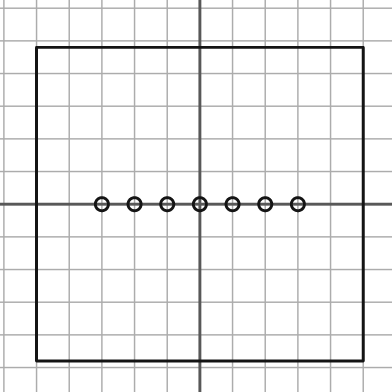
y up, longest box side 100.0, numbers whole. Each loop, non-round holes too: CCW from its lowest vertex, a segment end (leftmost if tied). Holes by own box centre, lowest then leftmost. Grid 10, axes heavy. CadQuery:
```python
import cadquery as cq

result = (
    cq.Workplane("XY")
    .moveTo(-50.0, -48.0)
    .lineTo(50.0, -48.0)
    .lineTo(50.0, 48.0)
    .lineTo(-50.0, 48.0)
    .close()
    .moveTo(-30.0, 0.0)
    .circle(2.0)
    .moveTo(-20.0, 0.0)
    .circle(2.0)
    .moveTo(-10.0, 0.0)
    .circle(2.0)
    .moveTo(0.0, 0.0)
    .circle(2.0)
    .moveTo(10.0, 0.0)
    .circle(2.0)
    .moveTo(20.0, 0.0)
    .circle(2.0)
    .moveTo(30.0, 0.0)
    .circle(2.0)
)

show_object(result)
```